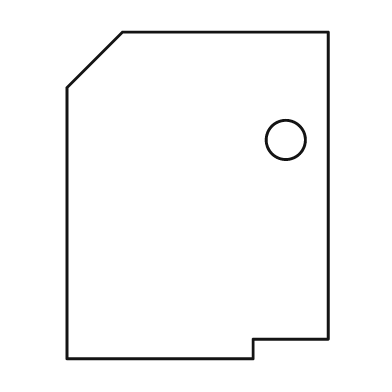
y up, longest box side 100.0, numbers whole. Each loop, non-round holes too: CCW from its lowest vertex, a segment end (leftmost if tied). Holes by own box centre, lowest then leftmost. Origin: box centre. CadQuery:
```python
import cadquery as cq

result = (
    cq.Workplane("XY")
    .moveTo(-40.0, -50.0)
    .lineTo(17.0, -50.0)
    .lineTo(17.0, -44.0)
    .lineTo(40.0, -44.0)
    .lineTo(40.0, 50.0)
    .lineTo(-23.0, 50.0)
    .lineTo(-40.0, 33.0)
    .close()
    .moveTo(27.0, 17.0)
    .circle(6.0)
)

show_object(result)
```